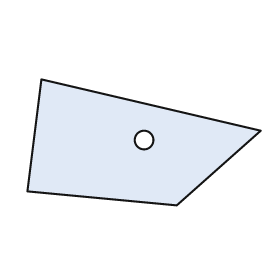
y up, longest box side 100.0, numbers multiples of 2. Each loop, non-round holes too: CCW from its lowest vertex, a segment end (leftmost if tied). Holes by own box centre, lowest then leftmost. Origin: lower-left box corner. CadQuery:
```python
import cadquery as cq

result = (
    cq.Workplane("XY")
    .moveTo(64.0, 0.0)
    .lineTo(100.0, 32.0)
    .lineTo(6.0, 54.0)
    .lineTo(0.0, 6.0)
    .close()
    .moveTo(50.0, 28.0)
    .circle(4.0)
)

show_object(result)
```